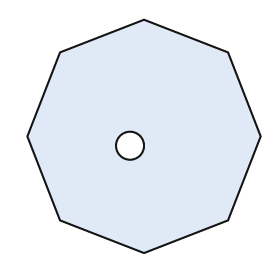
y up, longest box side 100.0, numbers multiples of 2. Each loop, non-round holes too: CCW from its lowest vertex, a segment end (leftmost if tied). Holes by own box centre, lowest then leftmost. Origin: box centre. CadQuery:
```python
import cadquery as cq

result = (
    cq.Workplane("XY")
    .moveTo(0.0, -50.0)
    .lineTo(36.0, -36.0)
    .lineTo(50.0, 0.0)
    .lineTo(36.0, 36.0)
    .lineTo(0.0, 50.0)
    .lineTo(-36.0, 36.0)
    .lineTo(-50.0, 0.0)
    .lineTo(-36.0, -36.0)
    .close()
    .moveTo(-6.0, -4.0)
    .circle(6.0)
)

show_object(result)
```